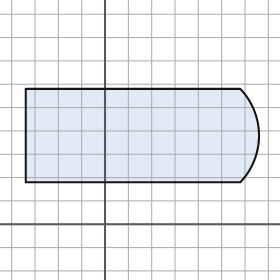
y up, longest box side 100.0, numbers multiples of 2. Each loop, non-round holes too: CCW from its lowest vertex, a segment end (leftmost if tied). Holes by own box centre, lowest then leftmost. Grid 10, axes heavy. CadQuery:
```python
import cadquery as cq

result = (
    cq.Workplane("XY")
    .moveTo(-34.0, 18.0)
    .lineTo(58.0, 18.0)
    .threePointArc((66.0, 38.0), (58.0, 58.0))
    .lineTo(-34.0, 58.0)
    .close()
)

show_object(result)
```